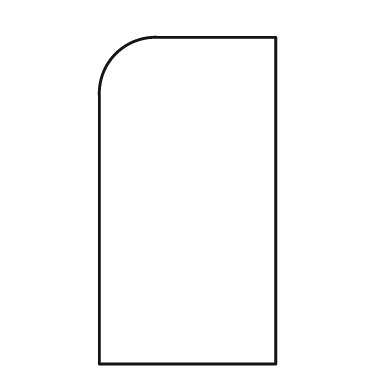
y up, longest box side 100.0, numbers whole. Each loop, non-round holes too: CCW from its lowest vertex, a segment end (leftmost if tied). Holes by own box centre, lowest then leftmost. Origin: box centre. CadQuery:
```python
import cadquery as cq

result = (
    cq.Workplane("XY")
    .moveTo(-27.0, -50.0)
    .lineTo(27.0, -50.0)
    .lineTo(27.0, 50.0)
    .lineTo(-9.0, 50.0)
    .threePointArc((-22.0, 45.0), (-27.0, 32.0))
    .close()
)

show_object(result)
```